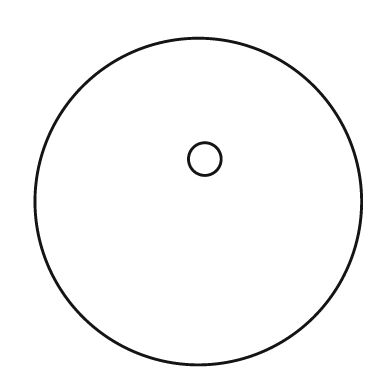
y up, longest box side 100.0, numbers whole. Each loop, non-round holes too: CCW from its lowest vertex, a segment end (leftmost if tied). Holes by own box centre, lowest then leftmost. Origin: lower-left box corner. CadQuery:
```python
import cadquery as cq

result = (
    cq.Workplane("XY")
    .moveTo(50.0, 50.0)
    .circle(50.0)
    .moveTo(52.0, 63.0)
    .circle(5.0)
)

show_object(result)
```